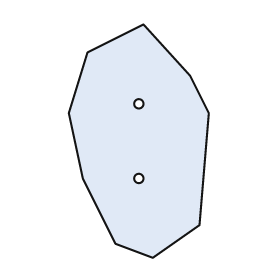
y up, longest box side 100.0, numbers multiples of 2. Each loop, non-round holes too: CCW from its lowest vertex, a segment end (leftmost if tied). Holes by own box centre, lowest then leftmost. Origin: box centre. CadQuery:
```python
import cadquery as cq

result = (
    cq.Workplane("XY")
    .moveTo(6.0, -50.0)
    .lineTo(26.0, -36.0)
    .lineTo(30.0, 12.0)
    .lineTo(22.0, 28.0)
    .lineTo(2.0, 50.0)
    .lineTo(-22.0, 38.0)
    .lineTo(-30.0, 12.0)
    .lineTo(-24.0, -16.0)
    .lineTo(-10.0, -44.0)
    .close()
    .moveTo(0.0, -16.0)
    .circle(2.0)
    .moveTo(0.0, 16.0)
    .circle(2.0)
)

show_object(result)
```